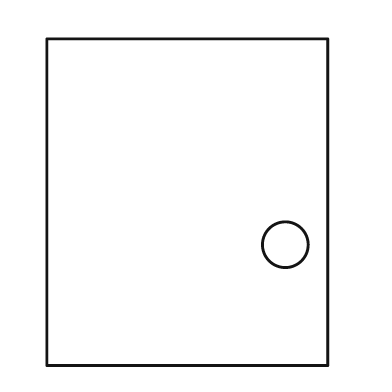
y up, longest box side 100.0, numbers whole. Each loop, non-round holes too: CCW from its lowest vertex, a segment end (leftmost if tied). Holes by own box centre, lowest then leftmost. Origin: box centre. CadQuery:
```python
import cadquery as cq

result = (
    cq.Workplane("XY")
    .moveTo(-43.0, -50.0)
    .lineTo(43.0, -50.0)
    .lineTo(43.0, 50.0)
    .lineTo(-43.0, 50.0)
    .close()
    .moveTo(30.0, -13.0)
    .circle(7.0)
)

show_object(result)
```